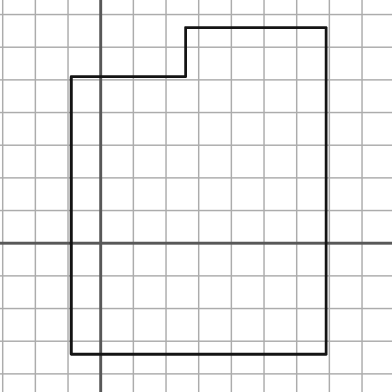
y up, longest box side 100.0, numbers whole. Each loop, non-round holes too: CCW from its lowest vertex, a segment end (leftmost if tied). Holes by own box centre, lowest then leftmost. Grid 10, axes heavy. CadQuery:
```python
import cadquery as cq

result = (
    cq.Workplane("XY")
    .moveTo(-9.0, -34.0)
    .lineTo(69.0, -34.0)
    .lineTo(69.0, 66.0)
    .lineTo(26.0, 66.0)
    .lineTo(26.0, 51.0)
    .lineTo(-9.0, 51.0)
    .close()
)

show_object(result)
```